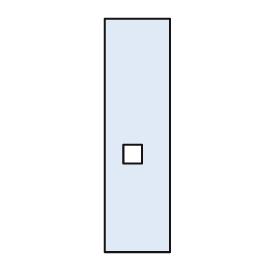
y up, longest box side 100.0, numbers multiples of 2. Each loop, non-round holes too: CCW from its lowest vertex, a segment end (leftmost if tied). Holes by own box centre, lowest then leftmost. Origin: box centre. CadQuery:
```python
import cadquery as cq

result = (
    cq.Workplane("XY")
    .moveTo(-14.0, -50.0)
    .lineTo(14.0, -50.0)
    .lineTo(14.0, 50.0)
    .lineTo(-14.0, 50.0)
    .close()
    .moveTo(-6.0, -12.0)
    .lineTo(2.0, -12.0)
    .lineTo(2.0, -4.0)
    .lineTo(-6.0, -4.0)
    .close()
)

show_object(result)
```